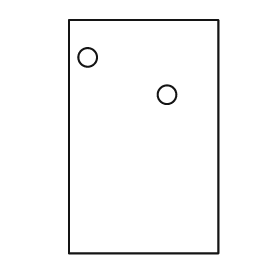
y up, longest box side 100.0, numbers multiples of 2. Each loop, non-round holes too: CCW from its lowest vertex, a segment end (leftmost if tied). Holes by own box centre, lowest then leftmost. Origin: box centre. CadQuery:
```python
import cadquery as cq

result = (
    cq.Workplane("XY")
    .moveTo(-32.0, -50.0)
    .lineTo(32.0, -50.0)
    .lineTo(32.0, 50.0)
    .lineTo(-32.0, 50.0)
    .close()
    .moveTo(10.0, 18.0)
    .circle(4.0)
    .moveTo(-24.0, 34.0)
    .circle(4.0)
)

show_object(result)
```